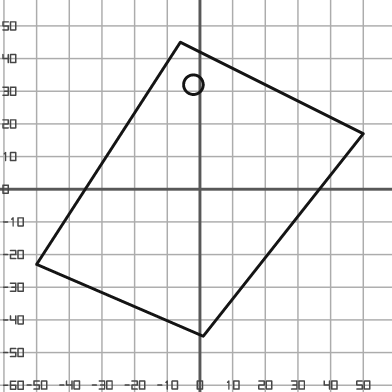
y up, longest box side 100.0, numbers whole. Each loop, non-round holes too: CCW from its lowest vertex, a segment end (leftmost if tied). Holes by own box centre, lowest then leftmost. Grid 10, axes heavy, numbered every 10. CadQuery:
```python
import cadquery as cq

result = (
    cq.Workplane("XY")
    .moveTo(1.0, -45.0)
    .lineTo(50.0, 17.0)
    .lineTo(-6.0, 45.0)
    .lineTo(-50.0, -23.0)
    .close()
    .moveTo(-2.0, 32.0)
    .circle(3.0)
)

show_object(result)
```